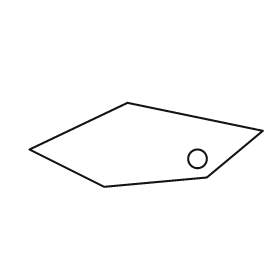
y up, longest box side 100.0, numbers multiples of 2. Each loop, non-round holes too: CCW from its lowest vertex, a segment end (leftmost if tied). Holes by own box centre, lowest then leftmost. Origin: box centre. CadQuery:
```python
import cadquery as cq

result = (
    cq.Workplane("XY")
    .moveTo(-18.0, -18.0)
    .lineTo(26.0, -14.0)
    .lineTo(50.0, 6.0)
    .lineTo(-8.0, 18.0)
    .lineTo(-50.0, -2.0)
    .close()
    .moveTo(22.0, -6.0)
    .circle(4.0)
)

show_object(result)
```